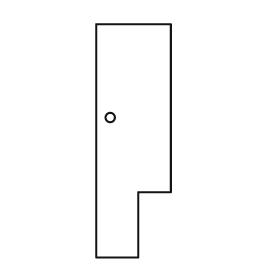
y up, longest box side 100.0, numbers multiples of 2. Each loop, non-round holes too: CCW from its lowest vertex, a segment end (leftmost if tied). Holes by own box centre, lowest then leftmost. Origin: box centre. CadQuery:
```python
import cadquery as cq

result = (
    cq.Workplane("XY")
    .moveTo(-16.0, -50.0)
    .lineTo(2.0, -50.0)
    .lineTo(2.0, -22.0)
    .lineTo(16.0, -22.0)
    .lineTo(16.0, 50.0)
    .lineTo(-16.0, 50.0)
    .close()
    .moveTo(-10.0, 10.0)
    .circle(2.0)
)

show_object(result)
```